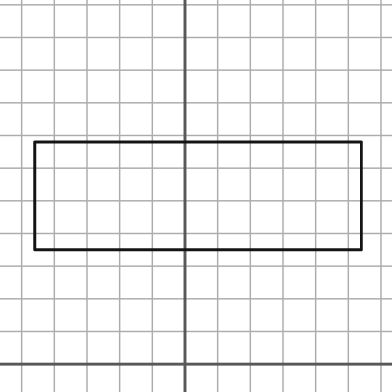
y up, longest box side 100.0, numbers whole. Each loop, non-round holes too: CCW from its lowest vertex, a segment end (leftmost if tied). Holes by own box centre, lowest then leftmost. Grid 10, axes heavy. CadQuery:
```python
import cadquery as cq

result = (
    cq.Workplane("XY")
    .moveTo(-46.0, 35.0)
    .lineTo(54.0, 35.0)
    .lineTo(54.0, 68.0)
    .lineTo(-46.0, 68.0)
    .close()
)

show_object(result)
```